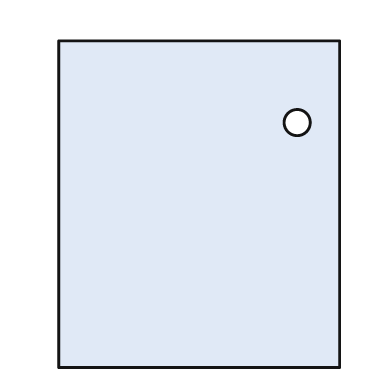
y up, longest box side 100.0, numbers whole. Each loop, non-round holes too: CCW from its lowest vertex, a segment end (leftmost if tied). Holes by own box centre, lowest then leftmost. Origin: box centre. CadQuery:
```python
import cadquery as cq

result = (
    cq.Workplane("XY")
    .moveTo(-43.0, -50.0)
    .lineTo(43.0, -50.0)
    .lineTo(43.0, 50.0)
    .lineTo(-43.0, 50.0)
    .close()
    .moveTo(30.0, 25.0)
    .circle(4.0)
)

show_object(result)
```